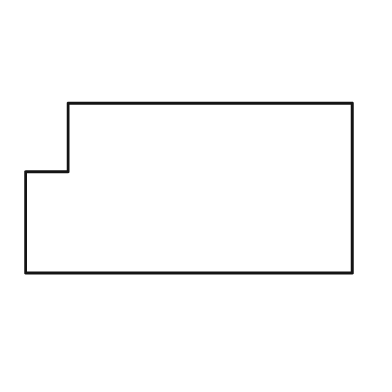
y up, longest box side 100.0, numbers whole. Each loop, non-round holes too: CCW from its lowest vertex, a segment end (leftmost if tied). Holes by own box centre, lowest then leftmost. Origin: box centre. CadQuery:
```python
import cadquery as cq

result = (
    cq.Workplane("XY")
    .moveTo(-50.0, -26.0)
    .lineTo(50.0, -26.0)
    .lineTo(50.0, 26.0)
    .lineTo(-37.0, 26.0)
    .lineTo(-37.0, 5.0)
    .lineTo(-50.0, 5.0)
    .close()
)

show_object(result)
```